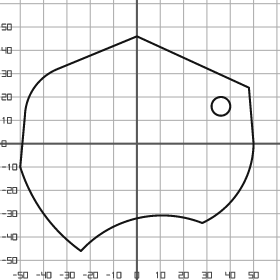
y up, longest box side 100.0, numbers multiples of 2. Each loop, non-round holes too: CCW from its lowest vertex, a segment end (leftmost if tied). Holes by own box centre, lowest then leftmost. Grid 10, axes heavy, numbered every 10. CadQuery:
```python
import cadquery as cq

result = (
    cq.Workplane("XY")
    .moveTo(-24.0, -46.0)
    .threePointArc((0.0, -32.0), (28.0, -34.0))
    .threePointArc((44.0, -20.0), (50.0, 0.0))
    .lineTo(48.0, 24.0)
    .lineTo(0.0, 46.0)
    .lineTo(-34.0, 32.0)
    .threePointArc((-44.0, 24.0), (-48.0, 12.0))
    .lineTo(-50.0, -10.0)
    .threePointArc((-40.0, -30.0), (-24.0, -46.0))
    .close()
    .moveTo(36.0, 16.0)
    .circle(4.0)
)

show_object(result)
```